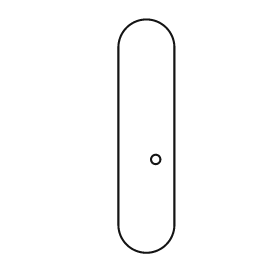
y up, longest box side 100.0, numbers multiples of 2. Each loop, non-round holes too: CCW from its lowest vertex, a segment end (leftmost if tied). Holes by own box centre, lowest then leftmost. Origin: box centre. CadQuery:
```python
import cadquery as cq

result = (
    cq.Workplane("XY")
    .moveTo(-12.0, -38.0)
    .threePointArc((0.0, -50.0), (12.0, -38.0))
    .lineTo(12.0, 38.0)
    .threePointArc((0.0, 50.0), (-12.0, 38.0))
    .close()
    .moveTo(4.0, -10.0)
    .circle(2.0)
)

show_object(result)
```